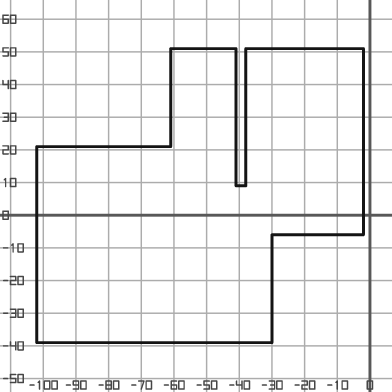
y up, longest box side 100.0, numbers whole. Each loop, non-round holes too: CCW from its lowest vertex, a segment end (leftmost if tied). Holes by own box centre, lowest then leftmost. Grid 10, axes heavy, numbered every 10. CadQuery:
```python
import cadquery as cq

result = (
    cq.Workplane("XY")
    .moveTo(-102.0, -39.0)
    .lineTo(-30.0, -39.0)
    .lineTo(-30.0, -6.0)
    .lineTo(-2.0, -6.0)
    .lineTo(-2.0, 51.0)
    .lineTo(-38.0, 51.0)
    .lineTo(-38.0, 9.0)
    .lineTo(-41.0, 9.0)
    .lineTo(-41.0, 51.0)
    .lineTo(-61.0, 51.0)
    .lineTo(-61.0, 21.0)
    .lineTo(-102.0, 21.0)
    .close()
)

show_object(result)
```